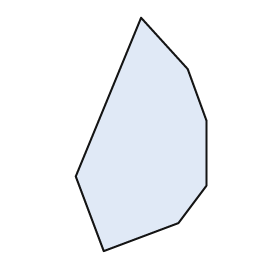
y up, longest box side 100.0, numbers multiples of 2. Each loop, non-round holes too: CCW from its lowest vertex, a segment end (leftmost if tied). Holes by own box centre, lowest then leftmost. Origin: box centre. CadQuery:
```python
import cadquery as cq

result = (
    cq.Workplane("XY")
    .moveTo(-16.0, -50.0)
    .lineTo(16.0, -38.0)
    .lineTo(28.0, -22.0)
    .lineTo(28.0, 6.0)
    .lineTo(20.0, 28.0)
    .lineTo(0.0, 50.0)
    .lineTo(-28.0, -18.0)
    .close()
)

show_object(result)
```